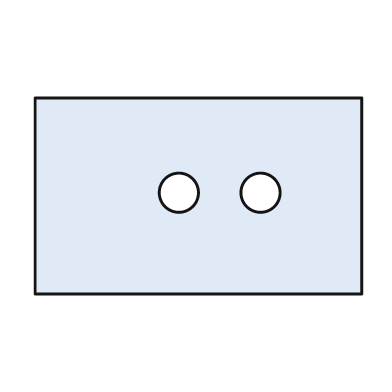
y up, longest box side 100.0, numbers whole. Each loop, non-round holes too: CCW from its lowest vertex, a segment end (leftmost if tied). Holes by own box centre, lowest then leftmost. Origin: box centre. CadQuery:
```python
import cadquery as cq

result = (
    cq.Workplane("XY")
    .moveTo(-50.0, -30.0)
    .lineTo(50.0, -30.0)
    .lineTo(50.0, 30.0)
    .lineTo(-50.0, 30.0)
    .close()
    .moveTo(-6.0, 1.0)
    .circle(6.0)
    .moveTo(19.0, 1.0)
    .circle(6.0)
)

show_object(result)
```